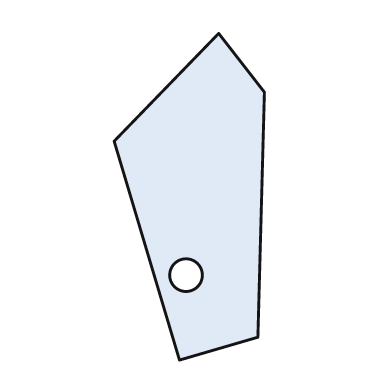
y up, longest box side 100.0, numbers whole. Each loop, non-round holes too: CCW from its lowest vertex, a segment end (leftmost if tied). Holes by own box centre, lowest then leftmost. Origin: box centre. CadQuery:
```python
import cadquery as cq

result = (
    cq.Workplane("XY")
    .moveTo(-3.0, -50.0)
    .lineTo(21.0, -43.0)
    .lineTo(23.0, 32.0)
    .lineTo(9.0, 50.0)
    .lineTo(-23.0, 17.0)
    .close()
    .moveTo(-1.0, -24.0)
    .circle(5.0)
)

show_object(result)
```